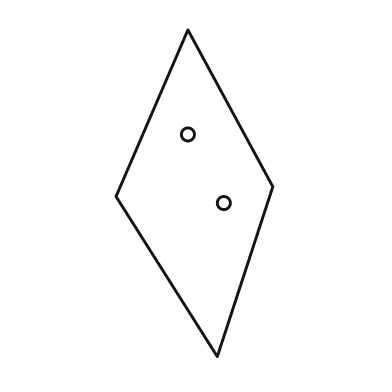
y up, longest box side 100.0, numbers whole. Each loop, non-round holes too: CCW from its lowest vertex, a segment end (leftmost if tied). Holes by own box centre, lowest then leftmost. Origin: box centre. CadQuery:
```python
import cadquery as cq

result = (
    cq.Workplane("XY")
    .moveTo(7.0, -50.0)
    .lineTo(24.0, 2.0)
    .lineTo(-2.0, 50.0)
    .lineTo(-24.0, -1.0)
    .close()
    .moveTo(9.0, -3.0)
    .circle(2.0)
    .moveTo(-2.0, 18.0)
    .circle(2.0)
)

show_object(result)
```